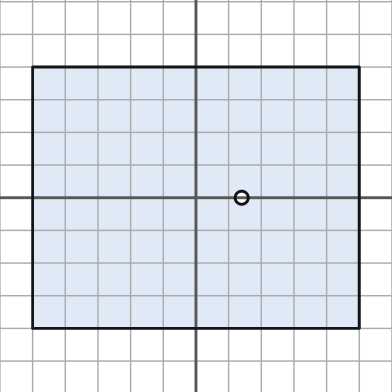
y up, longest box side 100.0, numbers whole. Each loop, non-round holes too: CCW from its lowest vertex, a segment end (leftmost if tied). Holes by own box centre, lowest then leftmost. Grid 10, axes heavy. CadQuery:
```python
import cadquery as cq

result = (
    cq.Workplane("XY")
    .moveTo(-50.0, -40.0)
    .lineTo(50.0, -40.0)
    .lineTo(50.0, 40.0)
    .lineTo(-50.0, 40.0)
    .close()
    .moveTo(14.0, 0.0)
    .circle(2.0)
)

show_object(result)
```